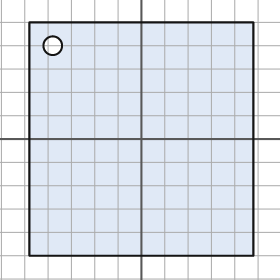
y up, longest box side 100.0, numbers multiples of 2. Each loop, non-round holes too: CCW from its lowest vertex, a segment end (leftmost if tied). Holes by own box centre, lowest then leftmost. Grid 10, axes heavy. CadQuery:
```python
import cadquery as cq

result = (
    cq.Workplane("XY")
    .moveTo(-48.0, -50.0)
    .lineTo(48.0, -50.0)
    .lineTo(48.0, 50.0)
    .lineTo(-48.0, 50.0)
    .close()
    .moveTo(-38.0, 40.0)
    .circle(4.0)
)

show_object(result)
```